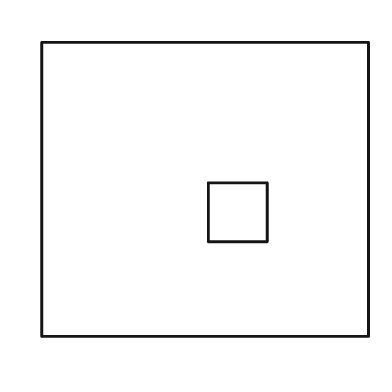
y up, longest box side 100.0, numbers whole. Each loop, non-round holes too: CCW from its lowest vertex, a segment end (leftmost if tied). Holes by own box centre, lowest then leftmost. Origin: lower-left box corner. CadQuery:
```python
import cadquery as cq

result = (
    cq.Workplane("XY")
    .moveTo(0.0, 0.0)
    .lineTo(100.0, 0.0)
    .lineTo(100.0, 90.0)
    .lineTo(0.0, 90.0)
    .close()
    .moveTo(51.0, 29.0)
    .lineTo(69.0, 29.0)
    .lineTo(69.0, 47.0)
    .lineTo(51.0, 47.0)
    .close()
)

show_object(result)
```